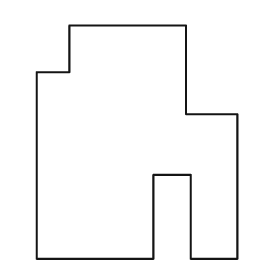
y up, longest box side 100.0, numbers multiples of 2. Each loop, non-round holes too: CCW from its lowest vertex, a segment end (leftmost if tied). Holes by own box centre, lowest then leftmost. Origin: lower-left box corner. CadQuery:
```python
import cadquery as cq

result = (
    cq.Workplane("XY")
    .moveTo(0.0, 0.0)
    .lineTo(50.0, 0.0)
    .lineTo(50.0, 36.0)
    .lineTo(66.0, 36.0)
    .lineTo(66.0, 0.0)
    .lineTo(86.0, 0.0)
    .lineTo(86.0, 62.0)
    .lineTo(64.0, 62.0)
    .lineTo(64.0, 100.0)
    .lineTo(14.0, 100.0)
    .lineTo(14.0, 80.0)
    .lineTo(0.0, 80.0)
    .close()
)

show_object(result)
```